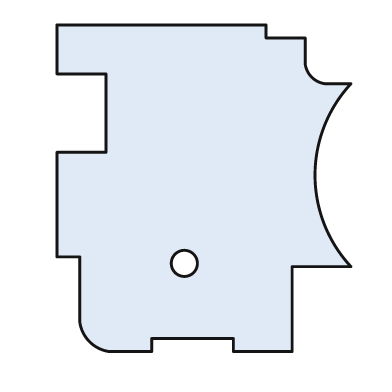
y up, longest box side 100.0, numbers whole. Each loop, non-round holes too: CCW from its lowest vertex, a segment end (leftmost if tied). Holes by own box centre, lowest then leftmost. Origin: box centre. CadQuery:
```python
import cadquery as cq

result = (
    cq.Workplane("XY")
    .moveTo(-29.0, -50.0)
    .lineTo(-16.0, -50.0)
    .lineTo(-16.0, -46.0)
    .lineTo(9.0, -46.0)
    .lineTo(9.0, -50.0)
    .lineTo(27.0, -50.0)
    .lineTo(27.0, -24.0)
    .lineTo(45.0, -24.0)
    .threePointArc((34.0, 4.0), (45.0, 32.0))
    .lineTo(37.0, 32.0)
    .threePointArc((33.0, 34.0), (31.0, 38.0))
    .lineTo(31.0, 46.0)
    .lineTo(19.0, 46.0)
    .lineTo(19.0, 50.0)
    .lineTo(-45.0, 50.0)
    .lineTo(-45.0, 35.0)
    .lineTo(-30.0, 35.0)
    .lineTo(-30.0, 11.0)
    .lineTo(-45.0, 11.0)
    .lineTo(-45.0, -21.0)
    .lineTo(-38.0, -21.0)
    .lineTo(-38.0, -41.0)
    .threePointArc((-35.0, -47.0), (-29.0, -50.0))
    .close()
    .moveTo(-6.0, -23.0)
    .circle(4.0)
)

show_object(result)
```